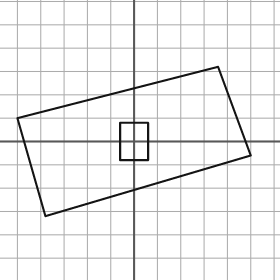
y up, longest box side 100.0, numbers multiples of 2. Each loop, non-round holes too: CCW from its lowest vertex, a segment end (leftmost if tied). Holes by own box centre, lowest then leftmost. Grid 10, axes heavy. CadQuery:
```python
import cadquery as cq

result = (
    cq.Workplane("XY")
    .moveTo(-38.0, -32.0)
    .lineTo(50.0, -6.0)
    .lineTo(36.0, 32.0)
    .lineTo(-50.0, 10.0)
    .close()
    .moveTo(-6.0, -8.0)
    .lineTo(6.0, -8.0)
    .lineTo(6.0, 8.0)
    .lineTo(-6.0, 8.0)
    .close()
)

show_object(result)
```